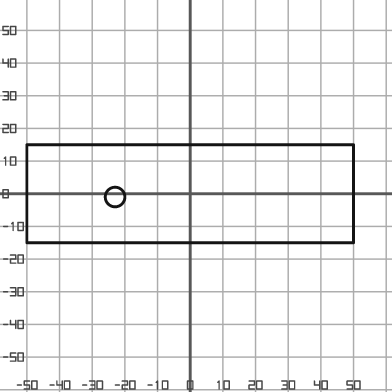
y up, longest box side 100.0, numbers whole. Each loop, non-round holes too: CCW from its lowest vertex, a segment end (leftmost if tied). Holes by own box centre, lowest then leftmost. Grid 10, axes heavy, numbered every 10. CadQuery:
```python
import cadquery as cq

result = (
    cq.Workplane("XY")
    .moveTo(-50.0, -15.0)
    .lineTo(50.0, -15.0)
    .lineTo(50.0, 15.0)
    .lineTo(-50.0, 15.0)
    .close()
    .moveTo(-23.0, -1.0)
    .circle(3.0)
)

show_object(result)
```